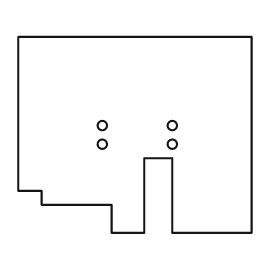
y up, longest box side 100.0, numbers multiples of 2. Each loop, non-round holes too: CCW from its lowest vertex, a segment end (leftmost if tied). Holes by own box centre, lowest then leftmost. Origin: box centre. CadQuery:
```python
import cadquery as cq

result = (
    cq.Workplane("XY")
    .moveTo(-10.0, -42.0)
    .lineTo(4.0, -42.0)
    .lineTo(4.0, -10.0)
    .lineTo(16.0, -10.0)
    .lineTo(16.0, -42.0)
    .lineTo(50.0, -42.0)
    .lineTo(50.0, 42.0)
    .lineTo(-50.0, 42.0)
    .lineTo(-50.0, -24.0)
    .lineTo(-40.0, -24.0)
    .lineTo(-40.0, -30.0)
    .lineTo(-10.0, -30.0)
    .close()
    .moveTo(-14.0, -4.0)
    .circle(2.0)
    .moveTo(16.0, -4.0)
    .circle(2.0)
    .moveTo(-14.0, 4.0)
    .circle(2.0)
    .moveTo(16.0, 4.0)
    .circle(2.0)
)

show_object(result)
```